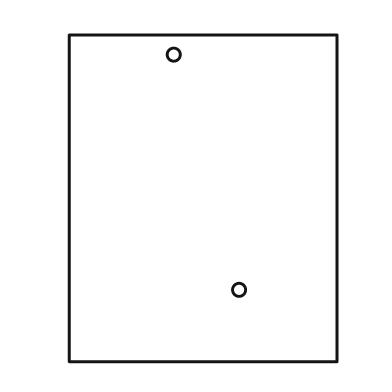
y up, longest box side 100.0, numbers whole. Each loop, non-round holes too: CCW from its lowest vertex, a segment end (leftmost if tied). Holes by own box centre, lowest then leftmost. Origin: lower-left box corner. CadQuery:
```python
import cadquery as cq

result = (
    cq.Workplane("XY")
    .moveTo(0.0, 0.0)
    .lineTo(82.0, 0.0)
    .lineTo(82.0, 100.0)
    .lineTo(0.0, 100.0)
    .close()
    .moveTo(52.0, 22.0)
    .circle(2.0)
    .moveTo(32.0, 94.0)
    .circle(2.0)
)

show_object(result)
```